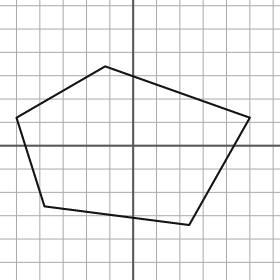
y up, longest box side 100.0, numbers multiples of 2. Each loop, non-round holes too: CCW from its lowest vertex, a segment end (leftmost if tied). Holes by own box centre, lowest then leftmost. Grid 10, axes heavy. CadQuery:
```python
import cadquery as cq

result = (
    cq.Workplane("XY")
    .moveTo(24.0, -34.0)
    .lineTo(50.0, 12.0)
    .lineTo(-12.0, 34.0)
    .lineTo(-50.0, 12.0)
    .lineTo(-38.0, -26.0)
    .close()
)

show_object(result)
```